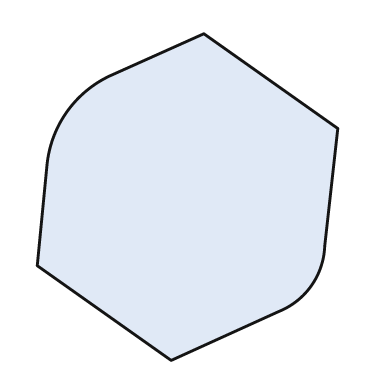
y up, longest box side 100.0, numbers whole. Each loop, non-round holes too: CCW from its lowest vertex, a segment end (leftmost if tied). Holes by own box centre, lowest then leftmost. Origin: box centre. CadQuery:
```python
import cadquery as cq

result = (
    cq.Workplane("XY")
    .moveTo(-5.0, -50.0)
    .lineTo(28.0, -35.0)
    .threePointArc((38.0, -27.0), (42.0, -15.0))
    .lineTo(46.0, 21.0)
    .lineTo(5.0, 50.0)
    .lineTo(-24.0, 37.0)
    .threePointArc((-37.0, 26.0), (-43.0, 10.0))
    .lineTo(-46.0, -21.0)
    .close()
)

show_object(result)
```